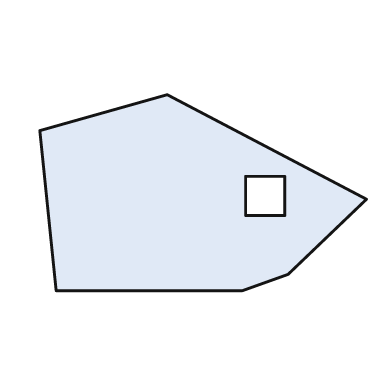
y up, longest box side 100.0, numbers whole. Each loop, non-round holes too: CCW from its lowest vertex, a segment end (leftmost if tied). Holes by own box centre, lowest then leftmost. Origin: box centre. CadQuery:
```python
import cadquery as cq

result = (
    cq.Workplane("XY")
    .moveTo(-45.0, -30.0)
    .lineTo(12.0, -30.0)
    .lineTo(26.0, -25.0)
    .lineTo(50.0, -2.0)
    .lineTo(-11.0, 30.0)
    .lineTo(-50.0, 19.0)
    .close()
    .moveTo(13.0, -7.0)
    .lineTo(25.0, -7.0)
    .lineTo(25.0, 5.0)
    .lineTo(13.0, 5.0)
    .close()
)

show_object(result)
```